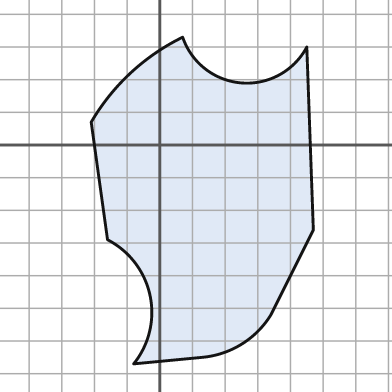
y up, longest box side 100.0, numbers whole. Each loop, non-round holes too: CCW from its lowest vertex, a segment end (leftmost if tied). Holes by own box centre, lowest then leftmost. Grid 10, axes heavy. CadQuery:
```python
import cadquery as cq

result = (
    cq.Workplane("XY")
    .moveTo(-8.0, -67.0)
    .lineTo(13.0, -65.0)
    .threePointArc((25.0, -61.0), (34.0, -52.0))
    .lineTo(47.0, -26.0)
    .lineTo(45.0, 30.0)
    .threePointArc((25.0, 19.0), (7.0, 33.0))
    .threePointArc((-9.0, 22.0), (-21.0, 7.0))
    .lineTo(-16.0, -29.0)
    .threePointArc((-3.0, -46.0), (-8.0, -67.0))
    .close()
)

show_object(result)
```